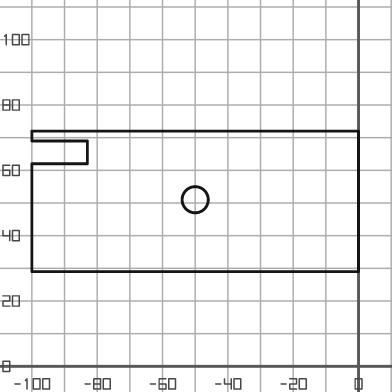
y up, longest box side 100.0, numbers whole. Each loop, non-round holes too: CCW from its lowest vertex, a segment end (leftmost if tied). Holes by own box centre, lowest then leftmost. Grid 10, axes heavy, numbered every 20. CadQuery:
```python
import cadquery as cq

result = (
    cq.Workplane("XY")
    .moveTo(-100.0, 29.0)
    .lineTo(0.0, 29.0)
    .lineTo(0.0, 72.0)
    .lineTo(-100.0, 72.0)
    .lineTo(-100.0, 69.0)
    .lineTo(-83.0, 69.0)
    .lineTo(-83.0, 62.0)
    .lineTo(-100.0, 62.0)
    .close()
    .moveTo(-50.0, 51.0)
    .circle(4.0)
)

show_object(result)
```